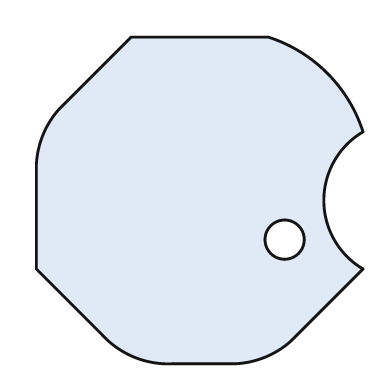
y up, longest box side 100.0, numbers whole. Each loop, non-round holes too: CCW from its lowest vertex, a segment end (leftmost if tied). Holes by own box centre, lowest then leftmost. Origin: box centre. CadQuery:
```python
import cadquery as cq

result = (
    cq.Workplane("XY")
    .moveTo(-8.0, -50.0)
    .lineTo(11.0, -50.0)
    .threePointArc((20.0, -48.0), (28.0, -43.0))
    .lineTo(50.0, -21.0)
    .threePointArc((38.0, 0.0), (50.0, 21.0))
    .threePointArc((39.0, 39.0), (21.0, 50.0))
    .lineTo(-21.0, 50.0)
    .lineTo(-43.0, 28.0)
    .threePointArc((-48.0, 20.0), (-50.0, 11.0))
    .lineTo(-50.0, -21.0)
    .lineTo(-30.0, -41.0)
    .threePointArc((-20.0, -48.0), (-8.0, -50.0))
    .close()
    .moveTo(26.0, -12.0)
    .circle(6.0)
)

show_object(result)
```